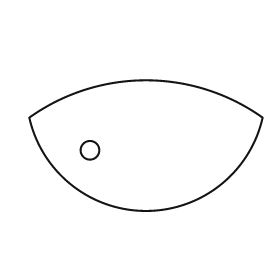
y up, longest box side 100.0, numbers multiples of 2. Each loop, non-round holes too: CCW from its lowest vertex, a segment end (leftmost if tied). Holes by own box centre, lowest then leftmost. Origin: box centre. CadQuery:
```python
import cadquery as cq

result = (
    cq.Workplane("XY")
    .moveTo(-50.0, 12.0)
    .threePointArc((0.0, -28.0), (50.0, 12.0))
    .threePointArc((0.0, 28.0), (-50.0, 12.0))
    .close()
    .moveTo(-24.0, -2.0)
    .circle(4.0)
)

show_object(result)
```